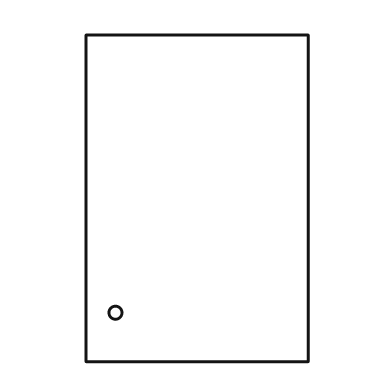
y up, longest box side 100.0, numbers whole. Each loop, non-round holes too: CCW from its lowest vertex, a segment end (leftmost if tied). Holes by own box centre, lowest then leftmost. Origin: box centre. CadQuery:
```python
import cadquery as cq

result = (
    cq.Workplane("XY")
    .moveTo(-34.0, -50.0)
    .lineTo(34.0, -50.0)
    .lineTo(34.0, 50.0)
    .lineTo(-34.0, 50.0)
    .close()
    .moveTo(-25.0, -35.0)
    .circle(2.0)
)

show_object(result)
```